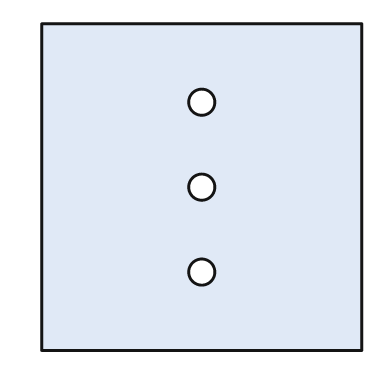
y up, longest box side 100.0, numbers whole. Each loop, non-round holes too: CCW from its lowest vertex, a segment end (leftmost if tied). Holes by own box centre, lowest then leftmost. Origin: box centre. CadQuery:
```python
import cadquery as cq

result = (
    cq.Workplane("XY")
    .moveTo(-49.0, -50.0)
    .lineTo(49.0, -50.0)
    .lineTo(49.0, 50.0)
    .lineTo(-49.0, 50.0)
    .close()
    .moveTo(0.0, -26.0)
    .circle(4.0)
    .moveTo(0.0, 0.0)
    .circle(4.0)
    .moveTo(0.0, 26.0)
    .circle(4.0)
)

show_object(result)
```